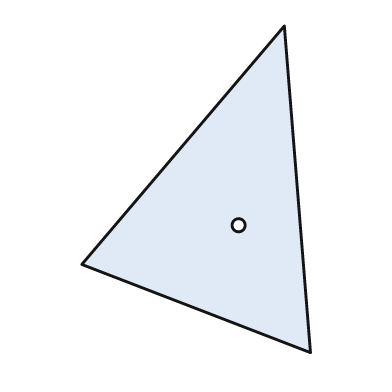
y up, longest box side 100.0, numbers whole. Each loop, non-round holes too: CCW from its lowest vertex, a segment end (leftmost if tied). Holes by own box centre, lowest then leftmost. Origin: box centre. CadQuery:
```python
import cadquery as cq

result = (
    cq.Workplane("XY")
    .moveTo(35.0, -50.0)
    .lineTo(27.0, 50.0)
    .lineTo(-35.0, -23.0)
    .close()
    .moveTo(13.0, -11.0)
    .circle(2.0)
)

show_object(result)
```